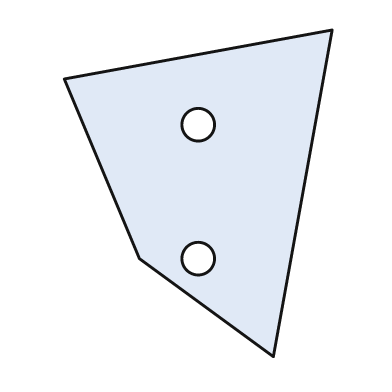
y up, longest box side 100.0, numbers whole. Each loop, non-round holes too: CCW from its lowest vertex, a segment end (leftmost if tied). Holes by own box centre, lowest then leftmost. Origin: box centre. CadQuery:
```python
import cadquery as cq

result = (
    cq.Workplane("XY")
    .moveTo(23.0, -50.0)
    .lineTo(41.0, 50.0)
    .lineTo(-41.0, 35.0)
    .lineTo(-18.0, -20.0)
    .close()
    .moveTo(0.0, -20.0)
    .circle(5.0)
    .moveTo(0.0, 21.0)
    .circle(5.0)
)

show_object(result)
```